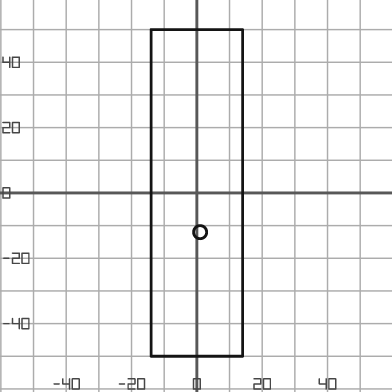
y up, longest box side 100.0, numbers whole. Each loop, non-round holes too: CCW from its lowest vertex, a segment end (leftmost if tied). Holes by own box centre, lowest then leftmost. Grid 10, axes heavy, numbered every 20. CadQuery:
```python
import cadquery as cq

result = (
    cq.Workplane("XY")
    .moveTo(-14.0, -50.0)
    .lineTo(14.0, -50.0)
    .lineTo(14.0, 50.0)
    .lineTo(-14.0, 50.0)
    .close()
    .moveTo(1.0, -12.0)
    .circle(2.0)
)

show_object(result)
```